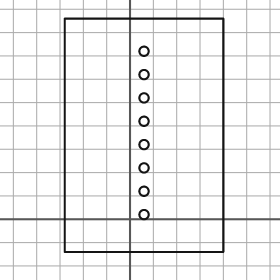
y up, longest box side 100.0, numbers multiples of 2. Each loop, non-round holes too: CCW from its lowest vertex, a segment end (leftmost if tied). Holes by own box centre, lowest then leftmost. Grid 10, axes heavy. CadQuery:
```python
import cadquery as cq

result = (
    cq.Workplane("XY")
    .moveTo(-28.0, -14.0)
    .lineTo(40.0, -14.0)
    .lineTo(40.0, 86.0)
    .lineTo(-28.0, 86.0)
    .close()
    .moveTo(6.0, 2.0)
    .circle(2.0)
    .moveTo(6.0, 12.0)
    .circle(2.0)
    .moveTo(6.0, 22.0)
    .circle(2.0)
    .moveTo(6.0, 32.0)
    .circle(2.0)
    .moveTo(6.0, 42.0)
    .circle(2.0)
    .moveTo(6.0, 52.0)
    .circle(2.0)
    .moveTo(6.0, 62.0)
    .circle(2.0)
    .moveTo(6.0, 72.0)
    .circle(2.0)
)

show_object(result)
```